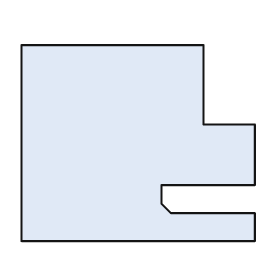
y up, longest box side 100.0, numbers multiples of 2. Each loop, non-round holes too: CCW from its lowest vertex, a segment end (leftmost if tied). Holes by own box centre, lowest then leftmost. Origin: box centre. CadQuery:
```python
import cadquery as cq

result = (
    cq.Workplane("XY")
    .moveTo(-50.0, -42.0)
    .lineTo(50.0, -42.0)
    .lineTo(50.0, -30.0)
    .lineTo(14.0, -30.0)
    .lineTo(10.0, -26.0)
    .lineTo(10.0, -18.0)
    .lineTo(50.0, -18.0)
    .lineTo(50.0, 8.0)
    .lineTo(28.0, 8.0)
    .lineTo(28.0, 42.0)
    .lineTo(-50.0, 42.0)
    .close()
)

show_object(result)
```